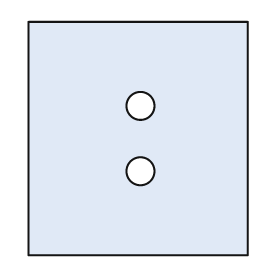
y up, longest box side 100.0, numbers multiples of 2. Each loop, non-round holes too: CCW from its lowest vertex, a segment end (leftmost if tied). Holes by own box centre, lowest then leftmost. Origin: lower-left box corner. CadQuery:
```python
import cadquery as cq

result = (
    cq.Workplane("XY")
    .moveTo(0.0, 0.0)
    .lineTo(94.0, 0.0)
    .lineTo(94.0, 100.0)
    .lineTo(0.0, 100.0)
    .close()
    .moveTo(48.0, 36.0)
    .circle(6.0)
    .moveTo(48.0, 64.0)
    .circle(6.0)
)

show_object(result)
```